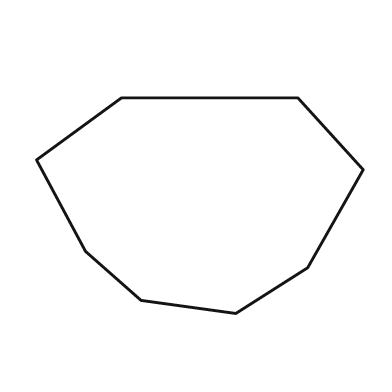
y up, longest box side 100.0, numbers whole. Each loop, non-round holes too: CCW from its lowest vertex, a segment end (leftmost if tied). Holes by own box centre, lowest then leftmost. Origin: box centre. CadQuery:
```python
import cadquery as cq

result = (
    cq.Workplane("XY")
    .moveTo(11.0, -33.0)
    .lineTo(33.0, -19.0)
    .lineTo(50.0, 11.0)
    .lineTo(30.0, 33.0)
    .lineTo(-24.0, 33.0)
    .lineTo(-50.0, 14.0)
    .lineTo(-35.0, -14.0)
    .lineTo(-18.0, -29.0)
    .close()
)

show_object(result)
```